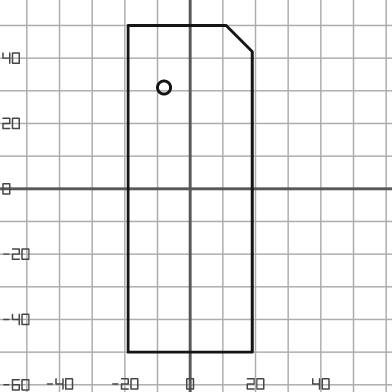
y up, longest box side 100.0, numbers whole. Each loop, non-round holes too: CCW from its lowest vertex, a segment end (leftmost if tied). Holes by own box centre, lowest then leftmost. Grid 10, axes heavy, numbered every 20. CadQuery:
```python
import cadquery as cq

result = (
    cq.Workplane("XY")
    .moveTo(-19.0, -50.0)
    .lineTo(19.0, -50.0)
    .lineTo(19.0, 42.0)
    .lineTo(11.0, 50.0)
    .lineTo(-19.0, 50.0)
    .close()
    .moveTo(-8.0, 31.0)
    .circle(2.0)
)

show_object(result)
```